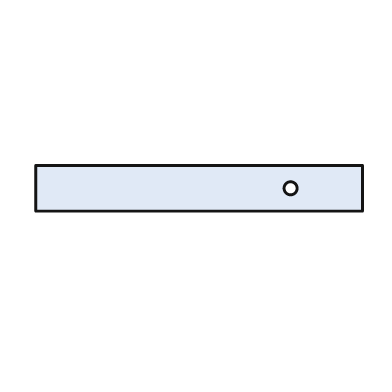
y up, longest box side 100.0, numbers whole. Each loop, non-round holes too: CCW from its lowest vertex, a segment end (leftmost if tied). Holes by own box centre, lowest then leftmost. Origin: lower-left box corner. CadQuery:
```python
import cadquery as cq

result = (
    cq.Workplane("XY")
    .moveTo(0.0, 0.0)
    .lineTo(100.0, 0.0)
    .lineTo(100.0, 14.0)
    .lineTo(0.0, 14.0)
    .close()
    .moveTo(78.0, 7.0)
    .circle(2.0)
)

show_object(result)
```